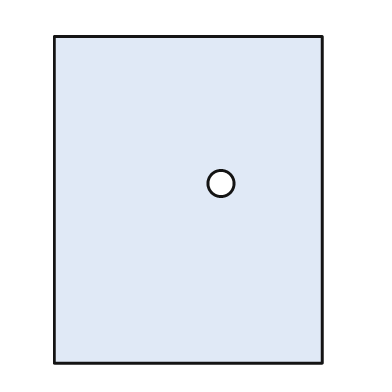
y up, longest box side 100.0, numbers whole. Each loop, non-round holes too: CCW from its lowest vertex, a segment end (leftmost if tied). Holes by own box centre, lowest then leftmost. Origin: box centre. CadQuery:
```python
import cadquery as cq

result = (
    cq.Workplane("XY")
    .moveTo(-41.0, -50.0)
    .lineTo(41.0, -50.0)
    .lineTo(41.0, 50.0)
    .lineTo(-41.0, 50.0)
    .close()
    .moveTo(10.0, 5.0)
    .circle(4.0)
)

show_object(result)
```